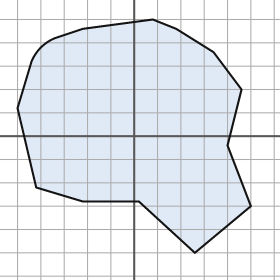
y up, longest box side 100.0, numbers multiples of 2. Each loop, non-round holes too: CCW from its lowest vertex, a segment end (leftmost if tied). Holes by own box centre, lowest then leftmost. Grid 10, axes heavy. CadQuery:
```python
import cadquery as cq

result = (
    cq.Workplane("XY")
    .moveTo(26.0, -50.0)
    .lineTo(50.0, -30.0)
    .lineTo(40.0, -4.0)
    .lineTo(46.0, 20.0)
    .lineTo(34.0, 36.0)
    .lineTo(18.0, 46.0)
    .lineTo(8.0, 50.0)
    .lineTo(-22.0, 46.0)
    .lineTo(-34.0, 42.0)
    .threePointArc((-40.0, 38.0), (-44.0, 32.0))
    .lineTo(-50.0, 12.0)
    .lineTo(-42.0, -22.0)
    .lineTo(-22.0, -28.0)
    .lineTo(2.0, -28.0)
    .close()
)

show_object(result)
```